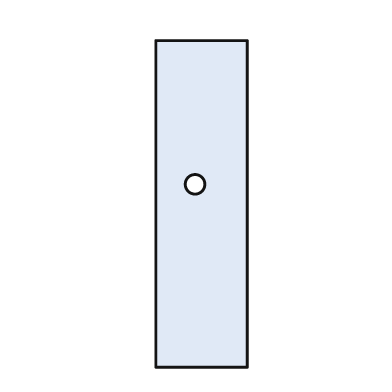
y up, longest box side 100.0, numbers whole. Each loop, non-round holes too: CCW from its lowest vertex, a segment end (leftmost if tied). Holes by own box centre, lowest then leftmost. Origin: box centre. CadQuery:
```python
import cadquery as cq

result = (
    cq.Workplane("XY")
    .moveTo(-14.0, -50.0)
    .lineTo(14.0, -50.0)
    .lineTo(14.0, 50.0)
    .lineTo(-14.0, 50.0)
    .close()
    .moveTo(-2.0, 6.0)
    .circle(3.0)
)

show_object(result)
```